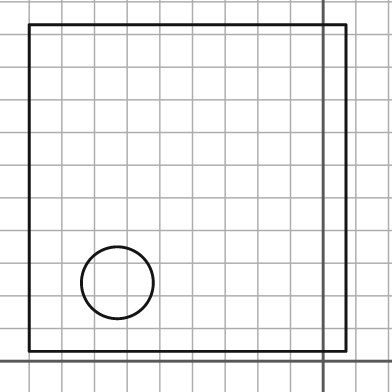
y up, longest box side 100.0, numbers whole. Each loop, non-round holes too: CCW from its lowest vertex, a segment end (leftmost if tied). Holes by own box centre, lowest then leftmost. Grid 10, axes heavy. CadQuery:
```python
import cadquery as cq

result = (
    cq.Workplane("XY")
    .moveTo(-90.0, 3.0)
    .lineTo(7.0, 3.0)
    .lineTo(7.0, 103.0)
    .lineTo(-90.0, 103.0)
    .close()
    .moveTo(-63.0, 24.0)
    .circle(11.0)
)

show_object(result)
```